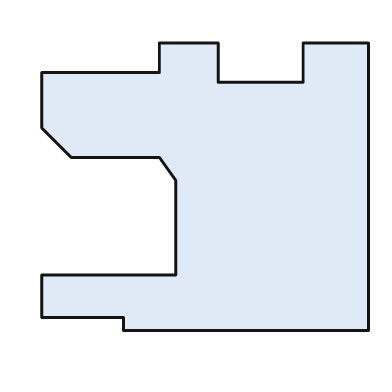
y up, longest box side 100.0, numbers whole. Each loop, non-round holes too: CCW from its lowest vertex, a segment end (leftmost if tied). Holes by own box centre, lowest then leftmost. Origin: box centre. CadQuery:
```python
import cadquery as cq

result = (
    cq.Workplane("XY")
    .moveTo(-25.0, -44.0)
    .lineTo(50.0, -44.0)
    .lineTo(50.0, 44.0)
    .lineTo(30.0, 44.0)
    .lineTo(30.0, 32.0)
    .lineTo(4.0, 32.0)
    .lineTo(4.0, 44.0)
    .lineTo(-14.0, 44.0)
    .lineTo(-14.0, 35.0)
    .lineTo(-50.0, 35.0)
    .lineTo(-50.0, 18.0)
    .lineTo(-41.0, 9.0)
    .lineTo(-14.0, 9.0)
    .lineTo(-9.0, 2.0)
    .lineTo(-9.0, -27.0)
    .lineTo(-50.0, -27.0)
    .lineTo(-50.0, -40.0)
    .lineTo(-25.0, -40.0)
    .close()
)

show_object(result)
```